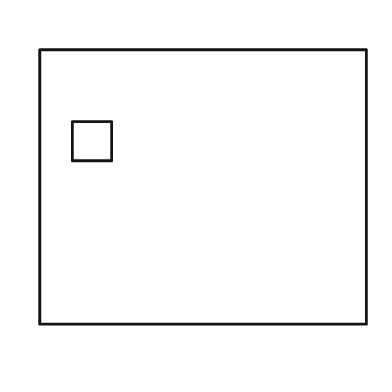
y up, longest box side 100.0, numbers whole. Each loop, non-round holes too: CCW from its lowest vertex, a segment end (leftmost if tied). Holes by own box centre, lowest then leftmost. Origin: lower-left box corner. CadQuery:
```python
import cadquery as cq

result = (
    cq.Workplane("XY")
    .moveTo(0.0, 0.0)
    .lineTo(100.0, 0.0)
    .lineTo(100.0, 84.0)
    .lineTo(0.0, 84.0)
    .close()
    .moveTo(10.0, 50.0)
    .lineTo(22.0, 50.0)
    .lineTo(22.0, 62.0)
    .lineTo(10.0, 62.0)
    .close()
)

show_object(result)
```